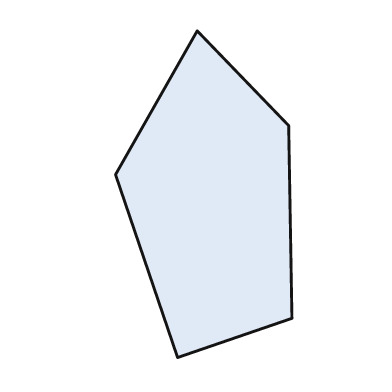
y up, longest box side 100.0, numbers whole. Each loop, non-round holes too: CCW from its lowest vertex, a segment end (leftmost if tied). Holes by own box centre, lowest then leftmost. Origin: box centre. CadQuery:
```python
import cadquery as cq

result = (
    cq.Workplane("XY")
    .moveTo(-8.0, -50.0)
    .lineTo(27.0, -38.0)
    .lineTo(26.0, 21.0)
    .lineTo(-2.0, 50.0)
    .lineTo(-27.0, 6.0)
    .close()
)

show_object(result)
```